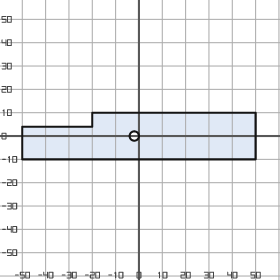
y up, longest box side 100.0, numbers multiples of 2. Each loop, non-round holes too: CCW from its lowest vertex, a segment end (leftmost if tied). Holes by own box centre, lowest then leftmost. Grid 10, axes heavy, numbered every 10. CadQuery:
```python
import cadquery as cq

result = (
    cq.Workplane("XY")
    .moveTo(-50.0, -10.0)
    .lineTo(50.0, -10.0)
    .lineTo(50.0, 10.0)
    .lineTo(-20.0, 10.0)
    .lineTo(-20.0, 4.0)
    .lineTo(-50.0, 4.0)
    .close()
    .moveTo(-2.0, 0.0)
    .circle(2.0)
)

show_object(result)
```